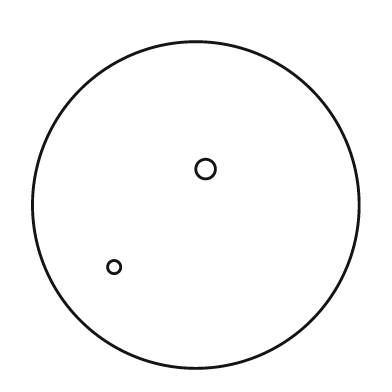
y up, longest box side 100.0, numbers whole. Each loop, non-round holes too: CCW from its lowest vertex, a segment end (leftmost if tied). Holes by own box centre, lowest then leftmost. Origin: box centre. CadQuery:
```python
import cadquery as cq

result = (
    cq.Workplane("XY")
    .moveTo(0.0, 0.0)
    .circle(50.0)
    .moveTo(-25.0, -19.0)
    .circle(2.0)
    .moveTo(3.0, 11.0)
    .circle(3.0)
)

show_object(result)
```